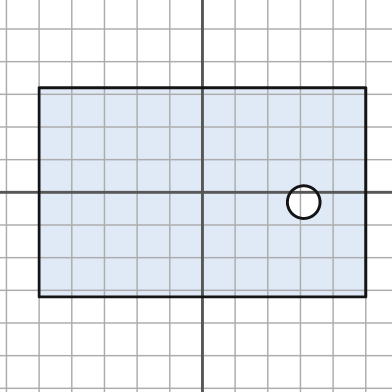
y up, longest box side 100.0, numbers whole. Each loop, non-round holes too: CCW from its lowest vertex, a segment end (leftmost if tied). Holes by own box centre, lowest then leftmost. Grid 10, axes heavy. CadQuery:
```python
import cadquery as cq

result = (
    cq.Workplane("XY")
    .moveTo(-50.0, -32.0)
    .lineTo(50.0, -32.0)
    .lineTo(50.0, 32.0)
    .lineTo(-50.0, 32.0)
    .close()
    .moveTo(31.0, -3.0)
    .circle(5.0)
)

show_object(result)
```